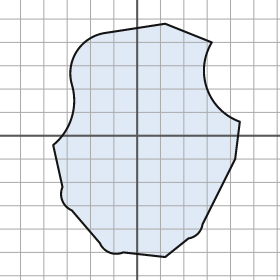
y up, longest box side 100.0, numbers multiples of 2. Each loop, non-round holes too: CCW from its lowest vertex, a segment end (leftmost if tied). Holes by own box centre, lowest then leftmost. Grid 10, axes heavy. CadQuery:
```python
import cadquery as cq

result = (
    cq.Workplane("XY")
    .moveTo(12.0, -52.0)
    .lineTo(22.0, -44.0)
    .threePointArc((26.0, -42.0), (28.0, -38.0))
    .lineTo(42.0, -10.0)
    .lineTo(44.0, 6.0)
    .threePointArc((30.0, 20.0), (32.0, 40.0))
    .lineTo(12.0, 48.0)
    .lineTo(-14.0, 44.0)
    .threePointArc((-26.0, 36.0), (-28.0, 22.0))
    .threePointArc((-28.0, 8.0), (-36.0, -4.0))
    .lineTo(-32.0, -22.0)
    .threePointArc((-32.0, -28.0), (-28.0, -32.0))
    .lineTo(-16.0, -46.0)
    .threePointArc((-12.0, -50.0), (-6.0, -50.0))
    .close()
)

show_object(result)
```